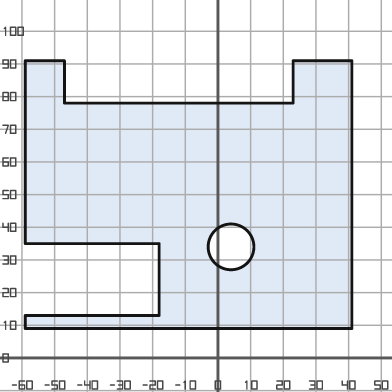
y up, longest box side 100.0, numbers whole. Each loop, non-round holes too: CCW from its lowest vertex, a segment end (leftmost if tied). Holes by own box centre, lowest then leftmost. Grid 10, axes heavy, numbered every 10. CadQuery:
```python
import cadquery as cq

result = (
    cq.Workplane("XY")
    .moveTo(-59.0, 9.0)
    .lineTo(41.0, 9.0)
    .lineTo(41.0, 91.0)
    .lineTo(23.0, 91.0)
    .lineTo(23.0, 78.0)
    .lineTo(-47.0, 78.0)
    .lineTo(-47.0, 91.0)
    .lineTo(-59.0, 91.0)
    .lineTo(-59.0, 35.0)
    .lineTo(-18.0, 35.0)
    .lineTo(-18.0, 13.0)
    .lineTo(-59.0, 13.0)
    .close()
    .moveTo(4.0, 34.0)
    .circle(7.0)
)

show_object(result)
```